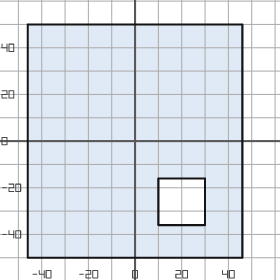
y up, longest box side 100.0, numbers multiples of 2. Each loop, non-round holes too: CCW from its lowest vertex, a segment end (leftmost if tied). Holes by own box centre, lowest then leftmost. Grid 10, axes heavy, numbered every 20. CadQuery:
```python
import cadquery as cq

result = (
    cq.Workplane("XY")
    .moveTo(-46.0, -50.0)
    .lineTo(46.0, -50.0)
    .lineTo(46.0, 50.0)
    .lineTo(-46.0, 50.0)
    .close()
    .moveTo(10.0, -36.0)
    .lineTo(30.0, -36.0)
    .lineTo(30.0, -16.0)
    .lineTo(10.0, -16.0)
    .close()
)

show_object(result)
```